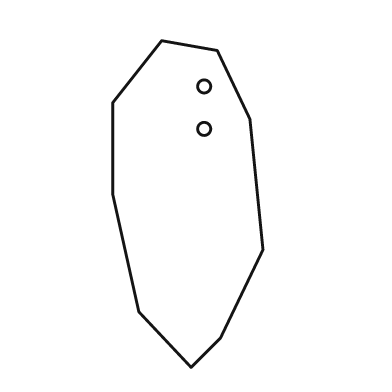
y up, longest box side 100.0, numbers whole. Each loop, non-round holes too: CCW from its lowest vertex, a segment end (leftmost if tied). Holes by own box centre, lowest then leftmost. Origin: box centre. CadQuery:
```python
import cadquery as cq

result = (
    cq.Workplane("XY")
    .moveTo(1.0, -50.0)
    .lineTo(10.0, -41.0)
    .lineTo(23.0, -14.0)
    .lineTo(19.0, 26.0)
    .lineTo(9.0, 47.0)
    .lineTo(-8.0, 50.0)
    .lineTo(-23.0, 31.0)
    .lineTo(-23.0, 3.0)
    .lineTo(-15.0, -33.0)
    .close()
    .moveTo(5.0, 23.0)
    .circle(2.0)
    .moveTo(5.0, 36.0)
    .circle(2.0)
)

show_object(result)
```